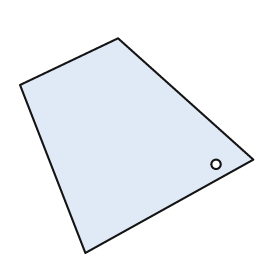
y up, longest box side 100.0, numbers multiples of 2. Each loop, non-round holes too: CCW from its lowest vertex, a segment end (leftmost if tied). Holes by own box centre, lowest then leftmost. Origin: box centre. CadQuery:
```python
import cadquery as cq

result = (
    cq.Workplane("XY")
    .moveTo(-22.0, -46.0)
    .lineTo(50.0, -6.0)
    .lineTo(-8.0, 46.0)
    .lineTo(-50.0, 26.0)
    .close()
    .moveTo(34.0, -8.0)
    .circle(2.0)
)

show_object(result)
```